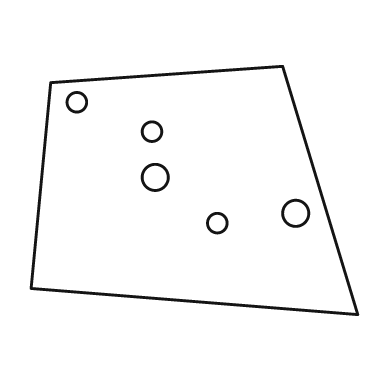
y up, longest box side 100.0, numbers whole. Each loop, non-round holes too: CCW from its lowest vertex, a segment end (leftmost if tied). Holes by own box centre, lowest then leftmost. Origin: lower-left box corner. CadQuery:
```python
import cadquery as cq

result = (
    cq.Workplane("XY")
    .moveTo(100.0, 0.0)
    .lineTo(77.0, 76.0)
    .lineTo(6.0, 71.0)
    .lineTo(0.0, 8.0)
    .close()
    .moveTo(57.0, 28.0)
    .circle(3.0)
    .moveTo(81.0, 31.0)
    .circle(4.0)
    .moveTo(38.0, 42.0)
    .circle(4.0)
    .moveTo(37.0, 56.0)
    .circle(3.0)
    .moveTo(14.0, 65.0)
    .circle(3.0)
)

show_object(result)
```